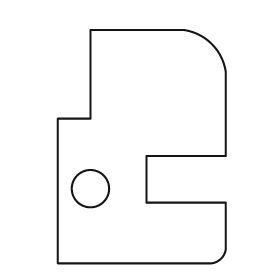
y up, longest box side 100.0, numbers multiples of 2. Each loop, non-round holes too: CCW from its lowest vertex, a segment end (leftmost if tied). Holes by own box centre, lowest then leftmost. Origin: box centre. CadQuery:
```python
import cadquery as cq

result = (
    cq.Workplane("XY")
    .moveTo(-36.0, -50.0)
    .lineTo(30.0, -50.0)
    .threePointArc((34.0, -48.0), (36.0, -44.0))
    .lineTo(36.0, -24.0)
    .lineTo(2.0, -24.0)
    .lineTo(2.0, -4.0)
    .lineTo(36.0, -4.0)
    .lineTo(36.0, 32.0)
    .threePointArc((30.0, 44.0), (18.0, 50.0))
    .lineTo(-22.0, 50.0)
    .lineTo(-22.0, 12.0)
    .lineTo(-36.0, 12.0)
    .close()
    .moveTo(-22.0, -18.0)
    .circle(8.0)
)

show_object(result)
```